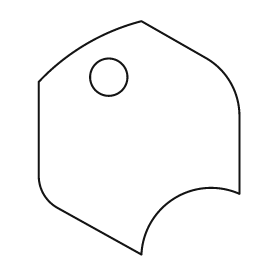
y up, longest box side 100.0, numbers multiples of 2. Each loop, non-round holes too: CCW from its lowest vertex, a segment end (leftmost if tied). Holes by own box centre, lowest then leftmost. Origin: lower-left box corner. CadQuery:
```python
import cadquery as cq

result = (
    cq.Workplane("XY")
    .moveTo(44.0, 0.0)
    .threePointArc((58.0, 24.0), (86.0, 26.0))
    .lineTo(86.0, 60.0)
    .threePointArc((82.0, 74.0), (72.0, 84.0))
    .lineTo(44.0, 100.0)
    .threePointArc((20.0, 90.0), (0.0, 74.0))
    .lineTo(0.0, 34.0)
    .threePointArc((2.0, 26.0), (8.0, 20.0))
    .close()
    .moveTo(30.0, 76.0)
    .circle(8.0)
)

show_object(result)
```